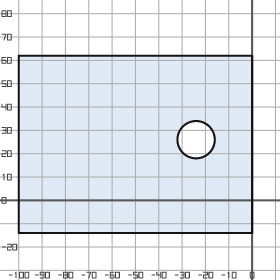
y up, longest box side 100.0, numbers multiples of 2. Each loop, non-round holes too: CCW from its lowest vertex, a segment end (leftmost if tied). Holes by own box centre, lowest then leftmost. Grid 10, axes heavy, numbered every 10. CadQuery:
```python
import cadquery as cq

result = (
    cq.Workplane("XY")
    .moveTo(-100.0, -14.0)
    .lineTo(0.0, -14.0)
    .lineTo(0.0, 62.0)
    .lineTo(-100.0, 62.0)
    .close()
    .moveTo(-24.0, 26.0)
    .circle(8.0)
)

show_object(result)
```